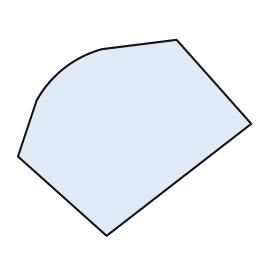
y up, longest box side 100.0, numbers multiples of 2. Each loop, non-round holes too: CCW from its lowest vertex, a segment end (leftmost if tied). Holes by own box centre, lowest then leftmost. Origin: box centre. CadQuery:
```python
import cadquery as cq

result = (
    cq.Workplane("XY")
    .moveTo(-12.0, -42.0)
    .lineTo(50.0, 6.0)
    .lineTo(18.0, 42.0)
    .lineTo(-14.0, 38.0)
    .threePointArc((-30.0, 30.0), (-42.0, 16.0))
    .lineTo(-50.0, -8.0)
    .close()
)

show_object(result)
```